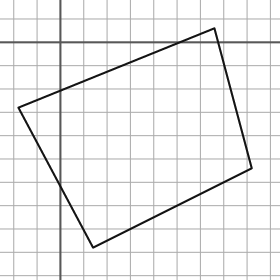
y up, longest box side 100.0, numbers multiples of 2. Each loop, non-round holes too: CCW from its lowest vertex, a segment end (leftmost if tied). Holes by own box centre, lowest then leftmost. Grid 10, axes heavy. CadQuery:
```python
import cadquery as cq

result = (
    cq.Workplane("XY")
    .moveTo(14.0, -88.0)
    .lineTo(82.0, -54.0)
    .lineTo(66.0, 6.0)
    .lineTo(-18.0, -28.0)
    .close()
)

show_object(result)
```